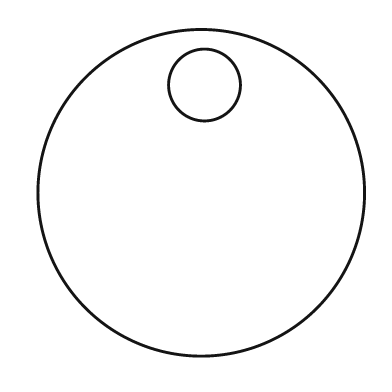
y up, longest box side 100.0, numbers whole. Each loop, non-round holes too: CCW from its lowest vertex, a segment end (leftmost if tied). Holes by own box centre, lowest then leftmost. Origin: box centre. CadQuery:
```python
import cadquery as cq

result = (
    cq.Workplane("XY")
    .moveTo(0.0, 0.0)
    .circle(50.0)
    .moveTo(1.0, 33.0)
    .circle(11.0)
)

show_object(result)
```